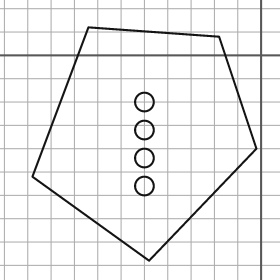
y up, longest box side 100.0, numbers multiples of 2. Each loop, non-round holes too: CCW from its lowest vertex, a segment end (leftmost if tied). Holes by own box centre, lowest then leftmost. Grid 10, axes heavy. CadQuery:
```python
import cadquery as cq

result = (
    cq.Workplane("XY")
    .moveTo(-48.0, -88.0)
    .lineTo(-2.0, -40.0)
    .lineTo(-18.0, 8.0)
    .lineTo(-74.0, 12.0)
    .lineTo(-98.0, -52.0)
    .close()
    .moveTo(-50.0, -56.0)
    .circle(4.0)
    .moveTo(-50.0, -44.0)
    .circle(4.0)
    .moveTo(-50.0, -32.0)
    .circle(4.0)
    .moveTo(-50.0, -20.0)
    .circle(4.0)
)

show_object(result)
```